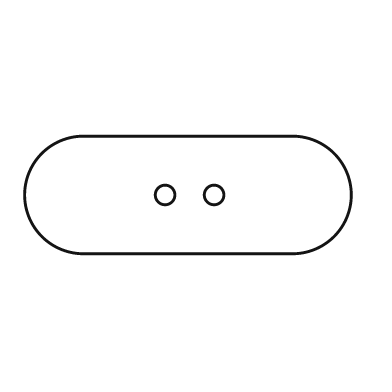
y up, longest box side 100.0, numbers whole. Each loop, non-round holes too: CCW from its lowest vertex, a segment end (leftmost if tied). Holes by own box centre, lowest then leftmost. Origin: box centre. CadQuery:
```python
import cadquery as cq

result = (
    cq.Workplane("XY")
    .moveTo(-32.0, -18.0)
    .lineTo(32.0, -18.0)
    .threePointArc((50.0, 0.0), (32.0, 18.0))
    .lineTo(-32.0, 18.0)
    .threePointArc((-50.0, 0.0), (-32.0, -18.0))
    .close()
    .moveTo(-7.0, 0.0)
    .circle(3.0)
    .moveTo(8.0, 0.0)
    .circle(3.0)
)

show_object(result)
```